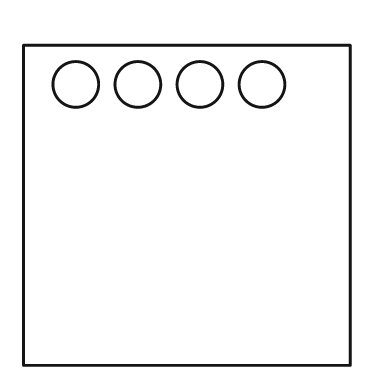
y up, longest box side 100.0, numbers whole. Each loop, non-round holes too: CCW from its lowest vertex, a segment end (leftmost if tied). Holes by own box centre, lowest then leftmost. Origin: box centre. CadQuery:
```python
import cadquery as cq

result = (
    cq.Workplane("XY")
    .moveTo(-50.0, -49.0)
    .lineTo(50.0, -49.0)
    .lineTo(50.0, 49.0)
    .lineTo(-50.0, 49.0)
    .close()
    .moveTo(-34.0, 37.0)
    .circle(7.0)
    .moveTo(-15.0, 37.0)
    .circle(7.0)
    .moveTo(4.0, 37.0)
    .circle(7.0)
    .moveTo(23.0, 37.0)
    .circle(7.0)
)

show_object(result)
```